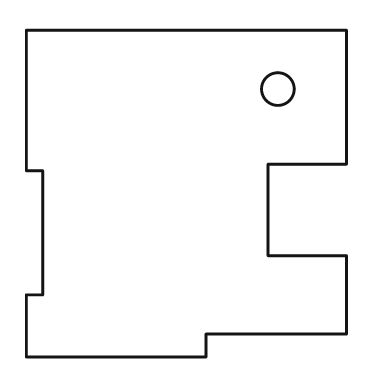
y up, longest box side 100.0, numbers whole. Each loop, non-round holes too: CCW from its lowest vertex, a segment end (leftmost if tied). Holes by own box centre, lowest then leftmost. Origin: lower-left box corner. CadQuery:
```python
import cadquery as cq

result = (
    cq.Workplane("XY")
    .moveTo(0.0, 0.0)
    .lineTo(55.0, 0.0)
    .lineTo(55.0, 7.0)
    .lineTo(98.0, 7.0)
    .lineTo(98.0, 31.0)
    .lineTo(74.0, 31.0)
    .lineTo(74.0, 59.0)
    .lineTo(98.0, 59.0)
    .lineTo(98.0, 100.0)
    .lineTo(0.0, 100.0)
    .lineTo(0.0, 57.0)
    .lineTo(5.0, 57.0)
    .lineTo(5.0, 19.0)
    .lineTo(0.0, 19.0)
    .close()
    .moveTo(77.0, 82.0)
    .circle(5.0)
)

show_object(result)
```